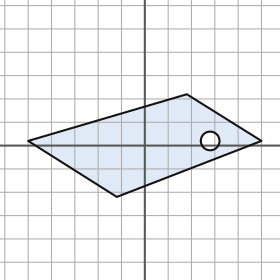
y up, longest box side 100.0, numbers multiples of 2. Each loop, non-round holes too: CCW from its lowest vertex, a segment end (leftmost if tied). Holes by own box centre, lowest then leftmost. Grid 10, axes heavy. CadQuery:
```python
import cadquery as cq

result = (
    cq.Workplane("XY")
    .moveTo(-12.0, -22.0)
    .lineTo(50.0, 2.0)
    .lineTo(18.0, 22.0)
    .lineTo(-50.0, 2.0)
    .close()
    .moveTo(28.0, 2.0)
    .circle(4.0)
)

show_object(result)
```